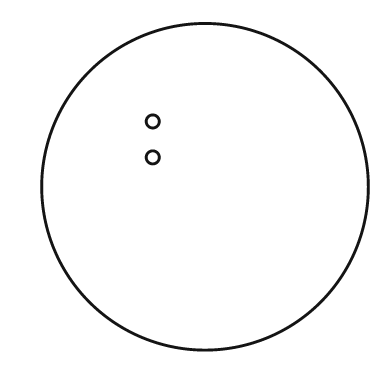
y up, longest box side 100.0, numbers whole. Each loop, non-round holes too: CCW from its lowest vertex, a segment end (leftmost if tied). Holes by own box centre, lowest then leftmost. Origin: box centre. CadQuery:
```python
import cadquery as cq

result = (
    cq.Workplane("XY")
    .moveTo(0.0, 0.0)
    .circle(50.0)
    .moveTo(-16.0, 9.0)
    .circle(2.0)
    .moveTo(-16.0, 20.0)
    .circle(2.0)
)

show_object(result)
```